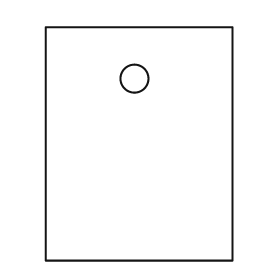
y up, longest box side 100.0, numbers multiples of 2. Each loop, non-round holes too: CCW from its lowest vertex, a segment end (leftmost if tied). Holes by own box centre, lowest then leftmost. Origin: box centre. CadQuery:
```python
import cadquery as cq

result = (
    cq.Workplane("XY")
    .moveTo(-40.0, -50.0)
    .lineTo(40.0, -50.0)
    .lineTo(40.0, 50.0)
    .lineTo(-40.0, 50.0)
    .close()
    .moveTo(-2.0, 28.0)
    .circle(6.0)
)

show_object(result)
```